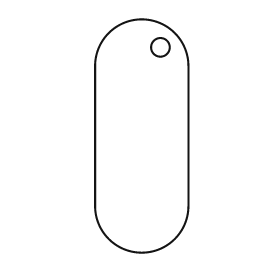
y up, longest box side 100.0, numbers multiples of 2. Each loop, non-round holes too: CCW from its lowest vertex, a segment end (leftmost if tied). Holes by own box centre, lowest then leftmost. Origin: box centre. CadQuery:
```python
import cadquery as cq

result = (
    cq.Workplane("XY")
    .moveTo(-20.0, -30.0)
    .threePointArc((0.0, -50.0), (20.0, -30.0))
    .lineTo(20.0, 30.0)
    .threePointArc((0.0, 50.0), (-20.0, 30.0))
    .close()
    .moveTo(8.0, 38.0)
    .circle(4.0)
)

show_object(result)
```